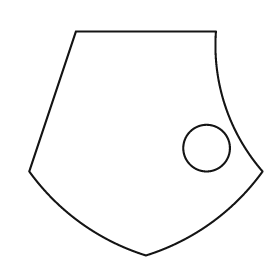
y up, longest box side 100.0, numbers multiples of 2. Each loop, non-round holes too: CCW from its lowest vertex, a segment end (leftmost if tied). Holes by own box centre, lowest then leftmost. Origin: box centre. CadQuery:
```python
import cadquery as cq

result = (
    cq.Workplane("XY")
    .moveTo(0.0, -48.0)
    .threePointArc((28.0, -34.0), (50.0, -12.0))
    .threePointArc((34.0, 16.0), (30.0, 48.0))
    .lineTo(-30.0, 48.0)
    .lineTo(-50.0, -12.0)
    .threePointArc((-28.0, -34.0), (0.0, -48.0))
    .close()
    .moveTo(26.0, -2.0)
    .circle(10.0)
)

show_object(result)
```